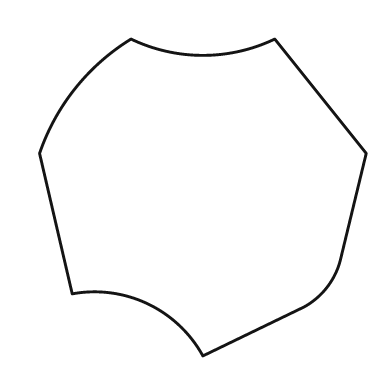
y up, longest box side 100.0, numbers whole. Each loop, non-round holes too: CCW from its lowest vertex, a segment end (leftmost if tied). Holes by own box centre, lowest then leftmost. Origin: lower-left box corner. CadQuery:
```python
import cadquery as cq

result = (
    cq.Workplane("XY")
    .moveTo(50.0, 0.0)
    .lineTo(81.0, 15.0)
    .threePointArc((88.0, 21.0), (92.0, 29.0))
    .lineTo(100.0, 62.0)
    .lineTo(72.0, 97.0)
    .threePointArc((50.0, 92.0), (28.0, 97.0))
    .threePointArc((11.0, 82.0), (0.0, 62.0))
    .lineTo(10.0, 19.0)
    .threePointArc((33.0, 16.0), (50.0, 0.0))
    .close()
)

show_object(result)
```